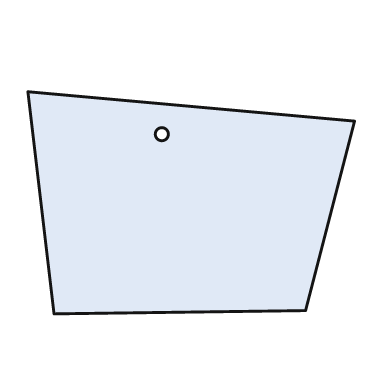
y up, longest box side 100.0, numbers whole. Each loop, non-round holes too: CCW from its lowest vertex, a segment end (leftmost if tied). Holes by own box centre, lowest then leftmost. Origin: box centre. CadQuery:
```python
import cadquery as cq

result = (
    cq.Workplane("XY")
    .moveTo(-42.0, -34.0)
    .lineTo(35.0, -33.0)
    .lineTo(50.0, 25.0)
    .lineTo(-50.0, 34.0)
    .close()
    .moveTo(-9.0, 21.0)
    .circle(2.0)
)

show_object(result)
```